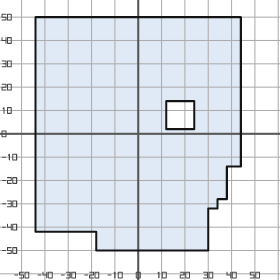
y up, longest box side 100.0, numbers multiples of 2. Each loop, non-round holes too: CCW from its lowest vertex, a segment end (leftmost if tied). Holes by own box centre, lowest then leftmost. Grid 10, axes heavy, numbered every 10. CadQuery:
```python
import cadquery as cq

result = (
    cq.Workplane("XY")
    .moveTo(-18.0, -50.0)
    .lineTo(30.0, -50.0)
    .lineTo(30.0, -32.0)
    .lineTo(34.0, -32.0)
    .lineTo(34.0, -28.0)
    .lineTo(38.0, -28.0)
    .lineTo(38.0, -14.0)
    .lineTo(44.0, -14.0)
    .lineTo(44.0, 50.0)
    .lineTo(-44.0, 50.0)
    .lineTo(-44.0, -42.0)
    .lineTo(-18.0, -42.0)
    .close()
    .moveTo(12.0, 2.0)
    .lineTo(24.0, 2.0)
    .lineTo(24.0, 14.0)
    .lineTo(12.0, 14.0)
    .close()
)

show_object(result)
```